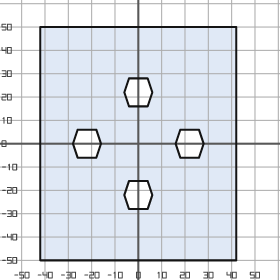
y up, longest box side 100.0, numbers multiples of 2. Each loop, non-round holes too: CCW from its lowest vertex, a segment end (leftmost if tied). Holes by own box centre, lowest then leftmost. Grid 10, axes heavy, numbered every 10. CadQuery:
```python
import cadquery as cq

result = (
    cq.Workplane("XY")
    .moveTo(-42.0, -50.0)
    .lineTo(42.0, -50.0)
    .lineTo(42.0, 50.0)
    .lineTo(-42.0, 50.0)
    .close()
    .moveTo(-4.0, -28.0)
    .lineTo(4.0, -28.0)
    .lineTo(6.0, -22.0)
    .lineTo(4.0, -16.0)
    .lineTo(-4.0, -16.0)
    .lineTo(-6.0, -22.0)
    .close()
    .moveTo(-26.0, -6.0)
    .lineTo(-18.0, -6.0)
    .lineTo(-16.0, 0.0)
    .lineTo(-18.0, 6.0)
    .lineTo(-26.0, 6.0)
    .lineTo(-28.0, 0.0)
    .close()
    .moveTo(18.0, -6.0)
    .lineTo(26.0, -6.0)
    .lineTo(28.0, 0.0)
    .lineTo(26.0, 6.0)
    .lineTo(18.0, 6.0)
    .lineTo(16.0, 0.0)
    .close()
    .moveTo(-4.0, 16.0)
    .lineTo(4.0, 16.0)
    .lineTo(6.0, 22.0)
    .lineTo(4.0, 28.0)
    .lineTo(-4.0, 28.0)
    .lineTo(-6.0, 22.0)
    .close()
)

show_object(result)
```